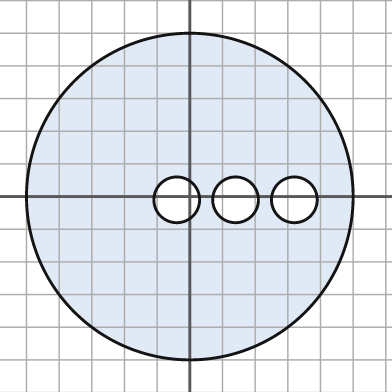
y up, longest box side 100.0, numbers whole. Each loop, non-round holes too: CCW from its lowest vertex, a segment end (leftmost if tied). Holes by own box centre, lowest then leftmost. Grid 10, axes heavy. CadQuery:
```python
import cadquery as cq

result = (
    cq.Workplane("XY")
    .moveTo(0.0, 0.0)
    .circle(50.0)
    .moveTo(-4.0, -1.0)
    .circle(7.0)
    .moveTo(14.0, -1.0)
    .circle(7.0)
    .moveTo(32.0, -1.0)
    .circle(7.0)
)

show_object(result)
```